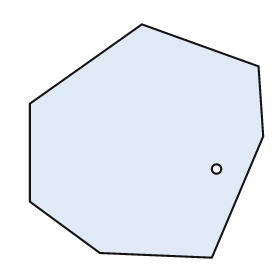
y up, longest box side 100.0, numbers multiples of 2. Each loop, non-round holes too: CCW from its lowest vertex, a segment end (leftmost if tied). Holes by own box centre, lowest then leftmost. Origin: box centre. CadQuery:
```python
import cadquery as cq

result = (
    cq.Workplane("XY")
    .moveTo(28.0, -50.0)
    .lineTo(50.0, 2.0)
    .lineTo(48.0, 32.0)
    .lineTo(-2.0, 50.0)
    .lineTo(-50.0, 16.0)
    .lineTo(-50.0, -26.0)
    .lineTo(-20.0, -48.0)
    .close()
    .moveTo(30.0, -12.0)
    .circle(2.0)
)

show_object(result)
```